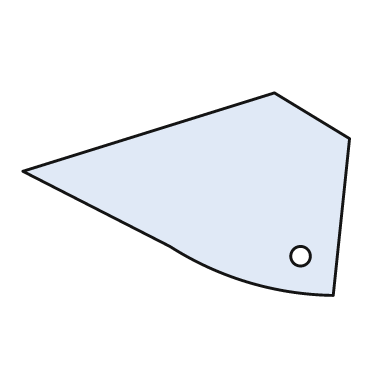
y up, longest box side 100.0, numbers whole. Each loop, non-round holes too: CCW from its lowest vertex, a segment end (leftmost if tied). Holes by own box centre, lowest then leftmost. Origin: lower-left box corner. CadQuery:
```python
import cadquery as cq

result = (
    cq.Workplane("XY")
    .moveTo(95.0, 0.0)
    .lineTo(100.0, 48.0)
    .lineTo(77.0, 62.0)
    .lineTo(0.0, 38.0)
    .lineTo(45.0, 15.0)
    .threePointArc((69.0, 4.0), (95.0, 0.0))
    .close()
    .moveTo(85.0, 12.0)
    .circle(3.0)
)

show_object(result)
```